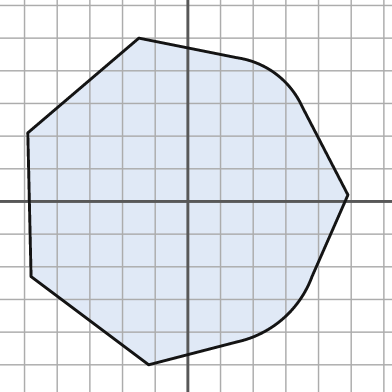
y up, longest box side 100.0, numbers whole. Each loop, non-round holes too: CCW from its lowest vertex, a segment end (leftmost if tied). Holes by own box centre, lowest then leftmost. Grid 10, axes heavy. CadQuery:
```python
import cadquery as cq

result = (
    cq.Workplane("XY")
    .moveTo(-12.0, -50.0)
    .lineTo(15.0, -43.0)
    .threePointArc((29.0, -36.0), (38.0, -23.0))
    .lineTo(49.0, 2.0)
    .lineTo(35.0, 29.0)
    .threePointArc((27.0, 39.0), (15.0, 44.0))
    .lineTo(-15.0, 50.0)
    .lineTo(-49.0, 21.0)
    .lineTo(-48.0, -23.0)
    .close()
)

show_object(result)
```